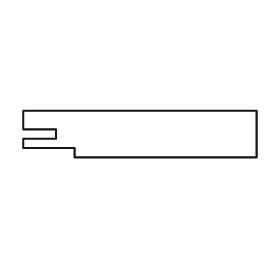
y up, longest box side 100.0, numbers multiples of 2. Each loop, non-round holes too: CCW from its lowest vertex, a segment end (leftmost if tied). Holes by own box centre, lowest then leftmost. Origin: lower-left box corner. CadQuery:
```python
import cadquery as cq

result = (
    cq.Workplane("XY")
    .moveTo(22.0, 0.0)
    .lineTo(100.0, 0.0)
    .lineTo(100.0, 20.0)
    .lineTo(0.0, 20.0)
    .lineTo(0.0, 12.0)
    .lineTo(14.0, 12.0)
    .lineTo(14.0, 8.0)
    .lineTo(0.0, 8.0)
    .lineTo(0.0, 4.0)
    .lineTo(22.0, 4.0)
    .close()
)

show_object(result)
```